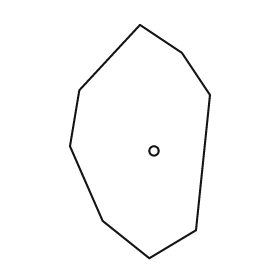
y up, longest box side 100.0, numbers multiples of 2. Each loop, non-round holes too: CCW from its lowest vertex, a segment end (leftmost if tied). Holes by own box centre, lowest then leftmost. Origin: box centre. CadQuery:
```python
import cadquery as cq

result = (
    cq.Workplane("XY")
    .moveTo(4.0, -50.0)
    .lineTo(24.0, -38.0)
    .lineTo(30.0, 20.0)
    .lineTo(18.0, 38.0)
    .lineTo(0.0, 50.0)
    .lineTo(-26.0, 22.0)
    .lineTo(-30.0, -2.0)
    .lineTo(-16.0, -34.0)
    .close()
    .moveTo(6.0, -4.0)
    .circle(2.0)
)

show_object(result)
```